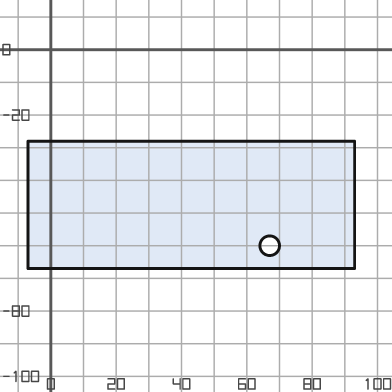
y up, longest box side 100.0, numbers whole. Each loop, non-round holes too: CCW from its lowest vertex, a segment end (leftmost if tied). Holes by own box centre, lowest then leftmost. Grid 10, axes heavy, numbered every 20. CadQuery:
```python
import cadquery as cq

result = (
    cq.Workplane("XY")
    .moveTo(-7.0, -67.0)
    .lineTo(93.0, -67.0)
    .lineTo(93.0, -28.0)
    .lineTo(-7.0, -28.0)
    .close()
    .moveTo(67.0, -60.0)
    .circle(3.0)
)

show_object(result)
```